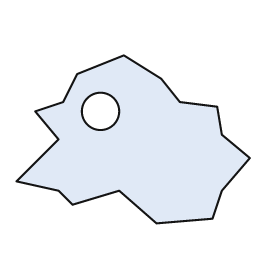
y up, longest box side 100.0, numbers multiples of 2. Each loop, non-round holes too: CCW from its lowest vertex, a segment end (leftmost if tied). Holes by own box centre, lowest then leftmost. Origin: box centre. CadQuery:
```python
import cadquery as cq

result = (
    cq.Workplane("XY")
    .moveTo(10.0, -36.0)
    .lineTo(34.0, -34.0)
    .lineTo(38.0, -22.0)
    .lineTo(50.0, -8.0)
    .lineTo(38.0, 2.0)
    .lineTo(36.0, 14.0)
    .lineTo(20.0, 16.0)
    .lineTo(12.0, 26.0)
    .lineTo(-4.0, 36.0)
    .lineTo(-24.0, 28.0)
    .lineTo(-30.0, 16.0)
    .lineTo(-42.0, 12.0)
    .lineTo(-32.0, 0.0)
    .lineTo(-50.0, -18.0)
    .lineTo(-32.0, -22.0)
    .lineTo(-26.0, -28.0)
    .lineTo(-6.0, -22.0)
    .close()
    .moveTo(-14.0, 12.0)
    .circle(8.0)
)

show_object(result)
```